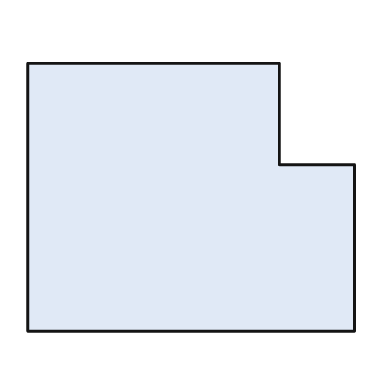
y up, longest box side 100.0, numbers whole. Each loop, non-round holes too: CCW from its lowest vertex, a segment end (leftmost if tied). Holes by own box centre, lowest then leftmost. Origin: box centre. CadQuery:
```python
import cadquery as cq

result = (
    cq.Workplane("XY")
    .moveTo(-50.0, -41.0)
    .lineTo(50.0, -41.0)
    .lineTo(50.0, 10.0)
    .lineTo(27.0, 10.0)
    .lineTo(27.0, 41.0)
    .lineTo(-50.0, 41.0)
    .close()
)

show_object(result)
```